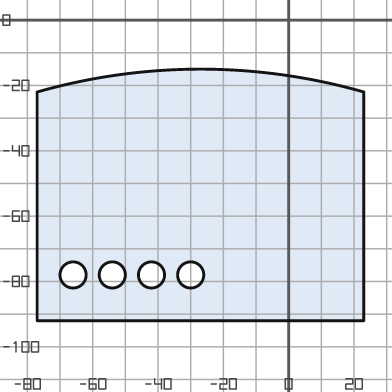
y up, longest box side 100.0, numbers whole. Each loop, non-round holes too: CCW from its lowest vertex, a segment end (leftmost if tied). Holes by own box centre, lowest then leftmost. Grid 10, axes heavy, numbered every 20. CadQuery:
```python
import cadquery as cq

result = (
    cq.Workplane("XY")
    .moveTo(-77.0, -92.0)
    .lineTo(23.0, -92.0)
    .lineTo(23.0, -22.0)
    .threePointArc((-27.0, -15.0), (-77.0, -22.0))
    .close()
    .moveTo(-66.0, -78.0)
    .circle(4.0)
    .moveTo(-54.0, -78.0)
    .circle(4.0)
    .moveTo(-42.0, -78.0)
    .circle(4.0)
    .moveTo(-30.0, -78.0)
    .circle(4.0)
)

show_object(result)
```